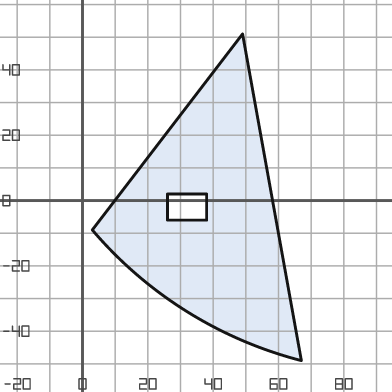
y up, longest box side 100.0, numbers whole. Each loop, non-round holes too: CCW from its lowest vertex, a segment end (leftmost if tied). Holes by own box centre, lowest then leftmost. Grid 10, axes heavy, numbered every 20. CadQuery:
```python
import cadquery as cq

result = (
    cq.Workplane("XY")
    .moveTo(67.0, -49.0)
    .lineTo(49.0, 51.0)
    .lineTo(3.0, -9.0)
    .threePointArc((32.0, -34.0), (67.0, -49.0))
    .close()
    .moveTo(26.0, -6.0)
    .lineTo(38.0, -6.0)
    .lineTo(38.0, 2.0)
    .lineTo(26.0, 2.0)
    .close()
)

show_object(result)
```